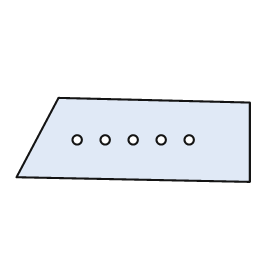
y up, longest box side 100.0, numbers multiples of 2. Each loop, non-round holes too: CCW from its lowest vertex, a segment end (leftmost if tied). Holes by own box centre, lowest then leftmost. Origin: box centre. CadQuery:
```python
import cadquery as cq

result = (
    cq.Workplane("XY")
    .moveTo(50.0, -18.0)
    .lineTo(50.0, 16.0)
    .lineTo(-32.0, 18.0)
    .lineTo(-50.0, -16.0)
    .close()
    .moveTo(-24.0, 0.0)
    .circle(2.0)
    .moveTo(-12.0, 0.0)
    .circle(2.0)
    .moveTo(0.0, 0.0)
    .circle(2.0)
    .moveTo(12.0, 0.0)
    .circle(2.0)
    .moveTo(24.0, 0.0)
    .circle(2.0)
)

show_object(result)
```